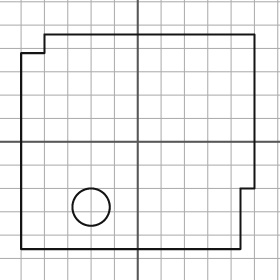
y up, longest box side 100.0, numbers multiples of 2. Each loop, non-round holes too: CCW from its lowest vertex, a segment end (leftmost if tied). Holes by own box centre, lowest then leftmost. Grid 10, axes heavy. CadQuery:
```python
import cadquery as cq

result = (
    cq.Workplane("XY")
    .moveTo(-50.0, -46.0)
    .lineTo(44.0, -46.0)
    .lineTo(44.0, -20.0)
    .lineTo(50.0, -20.0)
    .lineTo(50.0, 46.0)
    .lineTo(-40.0, 46.0)
    .lineTo(-40.0, 38.0)
    .lineTo(-50.0, 38.0)
    .close()
    .moveTo(-20.0, -28.0)
    .circle(8.0)
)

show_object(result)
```